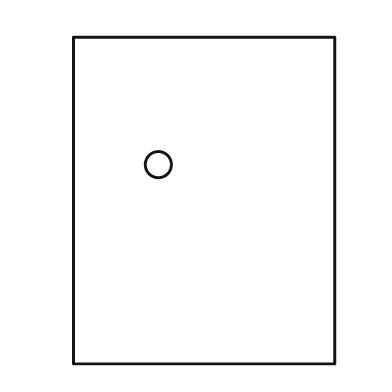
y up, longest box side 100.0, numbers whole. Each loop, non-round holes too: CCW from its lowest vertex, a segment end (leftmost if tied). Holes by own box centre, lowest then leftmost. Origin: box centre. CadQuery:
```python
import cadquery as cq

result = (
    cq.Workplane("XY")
    .moveTo(-40.0, -50.0)
    .lineTo(40.0, -50.0)
    .lineTo(40.0, 50.0)
    .lineTo(-40.0, 50.0)
    .close()
    .moveTo(-14.0, 11.0)
    .circle(4.0)
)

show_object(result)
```